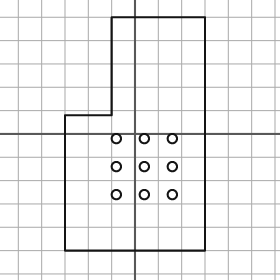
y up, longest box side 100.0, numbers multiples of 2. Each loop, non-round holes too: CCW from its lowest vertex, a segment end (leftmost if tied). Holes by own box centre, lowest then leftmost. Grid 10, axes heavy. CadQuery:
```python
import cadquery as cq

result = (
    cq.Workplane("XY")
    .moveTo(-30.0, -50.0)
    .lineTo(30.0, -50.0)
    .lineTo(30.0, 50.0)
    .lineTo(-10.0, 50.0)
    .lineTo(-10.0, 8.0)
    .lineTo(-30.0, 8.0)
    .close()
    .moveTo(-8.0, -26.0)
    .circle(2.0)
    .moveTo(4.0, -26.0)
    .circle(2.0)
    .moveTo(16.0, -26.0)
    .circle(2.0)
    .moveTo(-8.0, -14.0)
    .circle(2.0)
    .moveTo(4.0, -14.0)
    .circle(2.0)
    .moveTo(16.0, -14.0)
    .circle(2.0)
    .moveTo(-8.0, -2.0)
    .circle(2.0)
    .moveTo(4.0, -2.0)
    .circle(2.0)
    .moveTo(16.0, -2.0)
    .circle(2.0)
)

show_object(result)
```